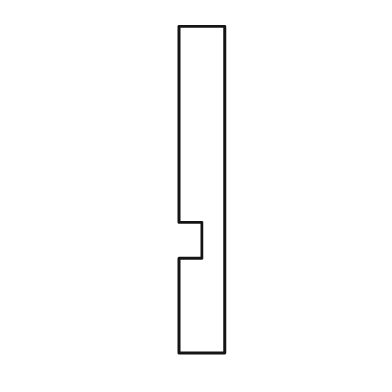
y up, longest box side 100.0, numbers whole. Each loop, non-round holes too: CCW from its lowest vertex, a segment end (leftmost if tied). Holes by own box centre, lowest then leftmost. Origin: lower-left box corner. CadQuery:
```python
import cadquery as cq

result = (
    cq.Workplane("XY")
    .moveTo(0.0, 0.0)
    .lineTo(14.0, 0.0)
    .lineTo(14.0, 100.0)
    .lineTo(0.0, 100.0)
    .lineTo(0.0, 40.0)
    .lineTo(7.0, 40.0)
    .lineTo(7.0, 29.0)
    .lineTo(0.0, 29.0)
    .close()
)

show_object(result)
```